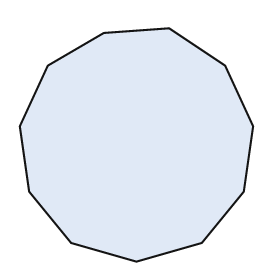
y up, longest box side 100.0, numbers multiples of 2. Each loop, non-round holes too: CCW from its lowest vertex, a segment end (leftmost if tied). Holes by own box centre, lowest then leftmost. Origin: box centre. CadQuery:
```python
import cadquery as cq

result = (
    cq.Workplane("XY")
    .moveTo(0.0, -50.0)
    .lineTo(28.0, -42.0)
    .lineTo(46.0, -20.0)
    .lineTo(50.0, 8.0)
    .lineTo(38.0, 34.0)
    .lineTo(14.0, 50.0)
    .lineTo(-14.0, 48.0)
    .lineTo(-38.0, 34.0)
    .lineTo(-50.0, 8.0)
    .lineTo(-46.0, -20.0)
    .lineTo(-28.0, -42.0)
    .close()
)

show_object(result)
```